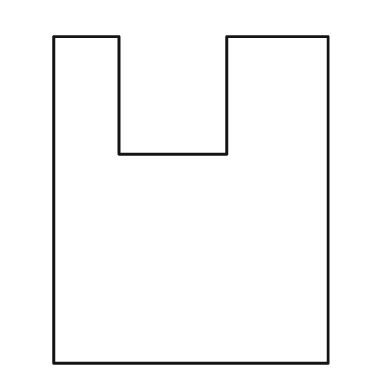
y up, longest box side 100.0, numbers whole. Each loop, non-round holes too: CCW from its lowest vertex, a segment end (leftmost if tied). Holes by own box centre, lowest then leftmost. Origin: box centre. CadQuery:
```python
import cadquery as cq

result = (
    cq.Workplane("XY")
    .moveTo(-42.0, -50.0)
    .lineTo(42.0, -50.0)
    .lineTo(42.0, 50.0)
    .lineTo(11.0, 50.0)
    .lineTo(11.0, 14.0)
    .lineTo(-22.0, 14.0)
    .lineTo(-22.0, 50.0)
    .lineTo(-42.0, 50.0)
    .close()
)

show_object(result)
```